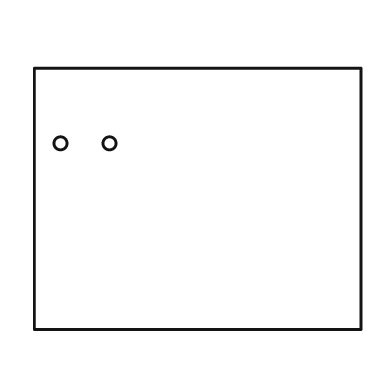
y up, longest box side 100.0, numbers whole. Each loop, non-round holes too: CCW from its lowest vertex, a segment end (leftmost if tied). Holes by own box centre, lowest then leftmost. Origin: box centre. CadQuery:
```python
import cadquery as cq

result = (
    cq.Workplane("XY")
    .moveTo(-50.0, -40.0)
    .lineTo(50.0, -40.0)
    .lineTo(50.0, 40.0)
    .lineTo(-50.0, 40.0)
    .close()
    .moveTo(-42.0, 17.0)
    .circle(2.0)
    .moveTo(-27.0, 17.0)
    .circle(2.0)
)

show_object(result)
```